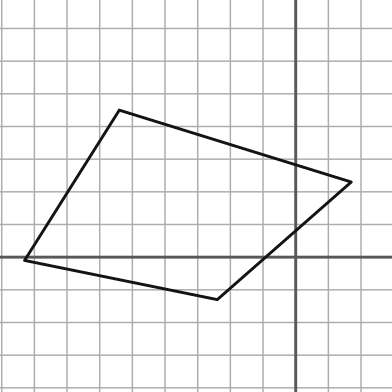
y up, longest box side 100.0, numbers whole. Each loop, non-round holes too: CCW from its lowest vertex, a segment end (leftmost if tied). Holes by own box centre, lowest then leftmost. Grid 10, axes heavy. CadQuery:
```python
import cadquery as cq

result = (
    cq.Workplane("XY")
    .moveTo(-24.0, -13.0)
    .lineTo(17.0, 23.0)
    .lineTo(-54.0, 45.0)
    .lineTo(-83.0, -1.0)
    .close()
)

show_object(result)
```